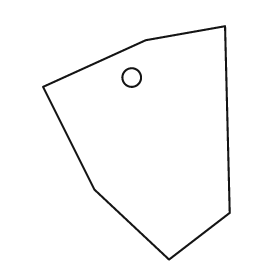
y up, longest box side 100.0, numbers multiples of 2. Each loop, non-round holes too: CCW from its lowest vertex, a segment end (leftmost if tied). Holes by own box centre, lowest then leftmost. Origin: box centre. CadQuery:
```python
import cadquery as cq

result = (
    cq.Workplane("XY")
    .moveTo(14.0, -50.0)
    .lineTo(40.0, -30.0)
    .lineTo(38.0, 50.0)
    .lineTo(4.0, 44.0)
    .lineTo(-40.0, 24.0)
    .lineTo(-18.0, -20.0)
    .close()
    .moveTo(-2.0, 28.0)
    .circle(4.0)
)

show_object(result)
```